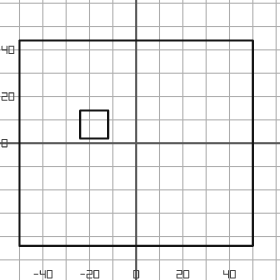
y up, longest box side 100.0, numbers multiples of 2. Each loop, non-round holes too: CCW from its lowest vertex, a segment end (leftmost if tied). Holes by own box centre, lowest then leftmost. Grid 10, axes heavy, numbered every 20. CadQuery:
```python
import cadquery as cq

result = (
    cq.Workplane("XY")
    .moveTo(-50.0, -44.0)
    .lineTo(50.0, -44.0)
    .lineTo(50.0, 44.0)
    .lineTo(-50.0, 44.0)
    .close()
    .moveTo(-24.0, 2.0)
    .lineTo(-12.0, 2.0)
    .lineTo(-12.0, 14.0)
    .lineTo(-24.0, 14.0)
    .close()
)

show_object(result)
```